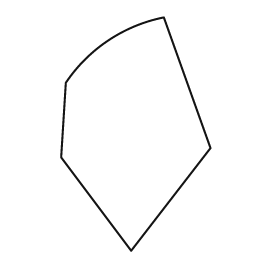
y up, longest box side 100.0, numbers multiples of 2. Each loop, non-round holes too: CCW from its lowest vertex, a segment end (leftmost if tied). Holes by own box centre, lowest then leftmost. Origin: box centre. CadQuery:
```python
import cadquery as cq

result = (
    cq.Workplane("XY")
    .moveTo(-2.0, -50.0)
    .lineTo(32.0, -6.0)
    .lineTo(12.0, 50.0)
    .threePointArc((-12.0, 40.0), (-30.0, 22.0))
    .lineTo(-32.0, -10.0)
    .close()
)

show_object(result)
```